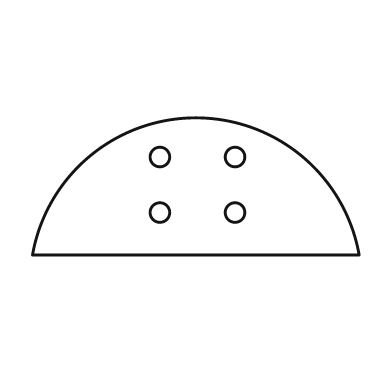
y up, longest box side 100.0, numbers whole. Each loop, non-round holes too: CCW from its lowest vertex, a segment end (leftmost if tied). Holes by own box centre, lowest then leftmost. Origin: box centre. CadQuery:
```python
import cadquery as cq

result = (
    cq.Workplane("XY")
    .moveTo(-50.0, -21.0)
    .lineTo(50.0, -21.0)
    .threePointArc((0.0, 21.0), (-50.0, -21.0))
    .close()
    .moveTo(-11.0, -8.0)
    .circle(3.0)
    .moveTo(12.0, -8.0)
    .circle(3.0)
    .moveTo(-11.0, 9.0)
    .circle(3.0)
    .moveTo(12.0, 9.0)
    .circle(3.0)
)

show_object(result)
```